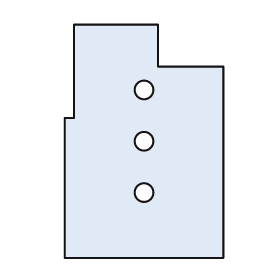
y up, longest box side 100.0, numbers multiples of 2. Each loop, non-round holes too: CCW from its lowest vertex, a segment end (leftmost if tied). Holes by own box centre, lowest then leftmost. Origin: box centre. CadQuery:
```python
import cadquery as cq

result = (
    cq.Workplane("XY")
    .moveTo(-34.0, -50.0)
    .lineTo(34.0, -50.0)
    .lineTo(34.0, 32.0)
    .lineTo(6.0, 32.0)
    .lineTo(6.0, 50.0)
    .lineTo(-30.0, 50.0)
    .lineTo(-30.0, 10.0)
    .lineTo(-34.0, 10.0)
    .close()
    .moveTo(0.0, -22.0)
    .circle(4.0)
    .moveTo(0.0, 0.0)
    .circle(4.0)
    .moveTo(0.0, 22.0)
    .circle(4.0)
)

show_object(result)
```